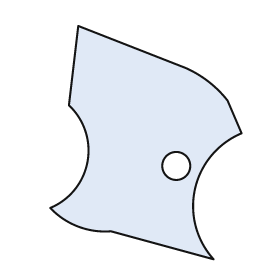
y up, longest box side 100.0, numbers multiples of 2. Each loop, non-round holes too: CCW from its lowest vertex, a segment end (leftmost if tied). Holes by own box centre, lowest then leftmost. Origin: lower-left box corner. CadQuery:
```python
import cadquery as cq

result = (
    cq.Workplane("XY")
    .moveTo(70.0, 0.0)
    .threePointArc((62.0, 30.0), (82.0, 54.0))
    .lineTo(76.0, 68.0)
    .threePointArc((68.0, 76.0), (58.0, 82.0))
    .lineTo(12.0, 100.0)
    .lineTo(8.0, 66.0)
    .threePointArc((16.0, 42.0), (0.0, 22.0))
    .threePointArc((12.0, 14.0), (26.0, 12.0))
    .close()
    .moveTo(54.0, 40.0)
    .circle(6.0)
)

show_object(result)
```